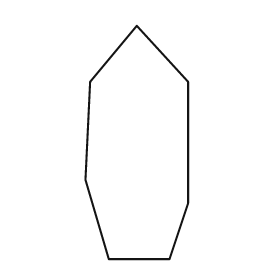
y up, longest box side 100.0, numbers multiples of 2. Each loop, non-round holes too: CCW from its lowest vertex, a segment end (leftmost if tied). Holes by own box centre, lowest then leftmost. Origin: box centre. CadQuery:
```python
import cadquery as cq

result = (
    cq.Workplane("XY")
    .moveTo(-12.0, -50.0)
    .lineTo(14.0, -50.0)
    .lineTo(22.0, -26.0)
    .lineTo(22.0, 26.0)
    .lineTo(0.0, 50.0)
    .lineTo(-20.0, 26.0)
    .lineTo(-22.0, -16.0)
    .close()
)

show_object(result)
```